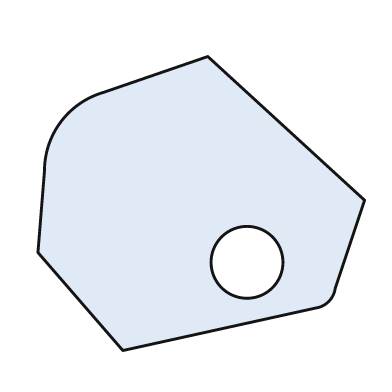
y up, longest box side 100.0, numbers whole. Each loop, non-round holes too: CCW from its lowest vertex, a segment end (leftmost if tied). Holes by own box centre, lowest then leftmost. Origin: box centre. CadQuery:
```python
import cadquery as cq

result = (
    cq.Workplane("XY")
    .moveTo(-24.0, -45.0)
    .lineTo(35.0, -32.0)
    .threePointArc((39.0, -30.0), (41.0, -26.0))
    .lineTo(50.0, 1.0)
    .lineTo(2.0, 45.0)
    .lineTo(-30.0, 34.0)
    .threePointArc((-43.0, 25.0), (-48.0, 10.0))
    .lineTo(-50.0, -15.0)
    .close()
    .moveTo(14.0, -18.0)
    .circle(11.0)
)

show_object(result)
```